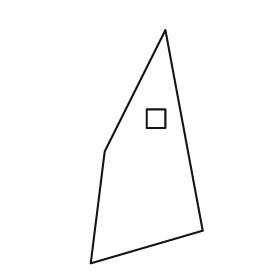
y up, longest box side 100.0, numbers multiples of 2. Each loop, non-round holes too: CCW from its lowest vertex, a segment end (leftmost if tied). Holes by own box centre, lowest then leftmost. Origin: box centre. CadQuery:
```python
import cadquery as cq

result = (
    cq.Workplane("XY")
    .moveTo(-24.0, -50.0)
    .lineTo(24.0, -36.0)
    .lineTo(8.0, 50.0)
    .lineTo(-18.0, -2.0)
    .close()
    .moveTo(0.0, 8.0)
    .lineTo(8.0, 8.0)
    .lineTo(8.0, 16.0)
    .lineTo(0.0, 16.0)
    .close()
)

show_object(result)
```